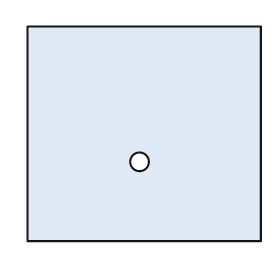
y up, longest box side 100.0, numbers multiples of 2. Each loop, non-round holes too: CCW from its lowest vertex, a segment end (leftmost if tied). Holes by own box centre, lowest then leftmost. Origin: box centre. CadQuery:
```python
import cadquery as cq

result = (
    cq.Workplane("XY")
    .moveTo(-50.0, -46.0)
    .lineTo(50.0, -46.0)
    .lineTo(50.0, 46.0)
    .lineTo(-50.0, 46.0)
    .close()
    .moveTo(-2.0, -12.0)
    .circle(4.0)
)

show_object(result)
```